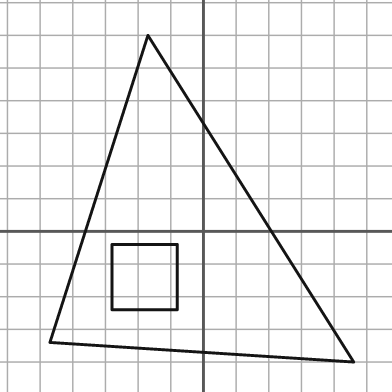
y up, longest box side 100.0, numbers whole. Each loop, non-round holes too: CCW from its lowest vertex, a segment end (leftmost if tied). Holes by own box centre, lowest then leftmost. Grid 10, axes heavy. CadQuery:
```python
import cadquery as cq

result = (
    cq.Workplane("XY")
    .moveTo(46.0, -40.0)
    .lineTo(-17.0, 60.0)
    .lineTo(-47.0, -34.0)
    .close()
    .moveTo(-28.0, -24.0)
    .lineTo(-8.0, -24.0)
    .lineTo(-8.0, -4.0)
    .lineTo(-28.0, -4.0)
    .close()
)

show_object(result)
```